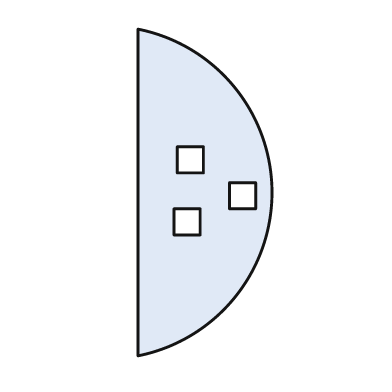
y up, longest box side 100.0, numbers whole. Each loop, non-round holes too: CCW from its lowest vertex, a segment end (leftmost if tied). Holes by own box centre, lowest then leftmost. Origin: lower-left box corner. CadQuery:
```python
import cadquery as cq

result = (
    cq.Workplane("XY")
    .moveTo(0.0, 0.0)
    .threePointArc((41.0, 50.0), (0.0, 100.0))
    .close()
    .moveTo(11.0, 37.0)
    .lineTo(19.0, 37.0)
    .lineTo(19.0, 45.0)
    .lineTo(11.0, 45.0)
    .close()
    .moveTo(28.0, 45.0)
    .lineTo(36.0, 45.0)
    .lineTo(36.0, 53.0)
    .lineTo(28.0, 53.0)
    .close()
    .moveTo(12.0, 56.0)
    .lineTo(20.0, 56.0)
    .lineTo(20.0, 64.0)
    .lineTo(12.0, 64.0)
    .close()
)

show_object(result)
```